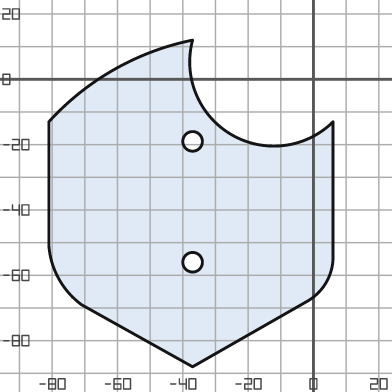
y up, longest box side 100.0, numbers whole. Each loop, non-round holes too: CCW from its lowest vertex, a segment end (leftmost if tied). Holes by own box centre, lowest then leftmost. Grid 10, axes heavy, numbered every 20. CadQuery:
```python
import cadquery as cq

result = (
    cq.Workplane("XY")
    .moveTo(-37.0, -88.0)
    .lineTo(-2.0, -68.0)
    .threePointArc((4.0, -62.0), (6.0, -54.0))
    .lineTo(6.0, -13.0)
    .threePointArc((-25.0, -17.0), (-37.0, 12.0))
    .threePointArc((-61.0, 3.0), (-81.0, -13.0))
    .lineTo(-81.0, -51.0)
    .threePointArc((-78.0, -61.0), (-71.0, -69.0))
    .close()
    .moveTo(-37.0, -56.0)
    .circle(3.0)
    .moveTo(-37.0, -19.0)
    .circle(3.0)
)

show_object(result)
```